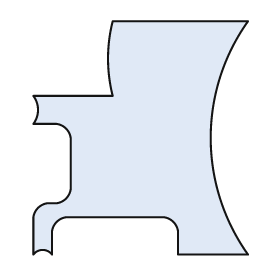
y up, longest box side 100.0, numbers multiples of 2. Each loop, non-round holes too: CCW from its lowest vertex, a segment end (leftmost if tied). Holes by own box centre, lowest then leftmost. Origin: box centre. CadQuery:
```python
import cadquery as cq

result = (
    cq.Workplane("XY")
    .moveTo(-46.0, -50.0)
    .threePointArc((-42.0, -48.0), (-38.0, -50.0))
    .lineTo(-38.0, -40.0)
    .threePointArc((-36.0, -36.0), (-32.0, -34.0))
    .lineTo(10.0, -34.0)
    .threePointArc((14.0, -36.0), (16.0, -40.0))
    .lineTo(16.0, -50.0)
    .lineTo(46.0, -50.0)
    .threePointArc((30.0, 0.0), (46.0, 50.0))
    .lineTo(-12.0, 50.0)
    .threePointArc((-14.0, 34.0), (-12.0, 18.0))
    .lineTo(-46.0, 18.0)
    .threePointArc((-44.0, 12.0), (-46.0, 6.0))
    .lineTo(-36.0, 6.0)
    .threePointArc((-32.0, 4.0), (-30.0, 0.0))
    .lineTo(-30.0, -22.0)
    .threePointArc((-32.0, -26.0), (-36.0, -28.0))
    .lineTo(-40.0, -28.0)
    .threePointArc((-44.0, -30.0), (-46.0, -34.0))
    .close()
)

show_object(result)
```